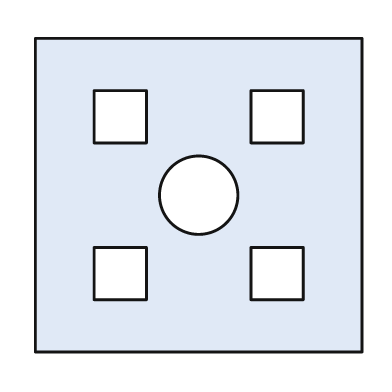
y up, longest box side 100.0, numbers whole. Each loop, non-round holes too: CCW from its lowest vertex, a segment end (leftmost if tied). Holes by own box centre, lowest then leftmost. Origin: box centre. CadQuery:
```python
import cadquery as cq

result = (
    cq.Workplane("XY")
    .moveTo(-50.0, -48.0)
    .lineTo(50.0, -48.0)
    .lineTo(50.0, 48.0)
    .lineTo(-50.0, 48.0)
    .close()
    .moveTo(-32.0, -32.0)
    .lineTo(-16.0, -32.0)
    .lineTo(-16.0, -16.0)
    .lineTo(-32.0, -16.0)
    .close()
    .moveTo(16.0, -32.0)
    .lineTo(32.0, -32.0)
    .lineTo(32.0, -16.0)
    .lineTo(16.0, -16.0)
    .close()
    .moveTo(0.0, 0.0)
    .circle(12.0)
    .moveTo(-32.0, 16.0)
    .lineTo(-16.0, 16.0)
    .lineTo(-16.0, 32.0)
    .lineTo(-32.0, 32.0)
    .close()
    .moveTo(16.0, 16.0)
    .lineTo(32.0, 16.0)
    .lineTo(32.0, 32.0)
    .lineTo(16.0, 32.0)
    .close()
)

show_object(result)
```